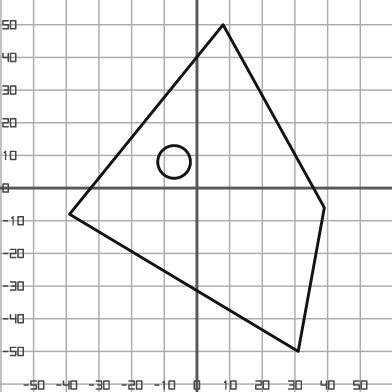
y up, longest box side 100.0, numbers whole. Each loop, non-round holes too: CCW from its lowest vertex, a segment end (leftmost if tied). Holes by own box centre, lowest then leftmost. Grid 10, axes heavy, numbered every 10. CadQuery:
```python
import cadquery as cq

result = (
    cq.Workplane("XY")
    .moveTo(31.0, -50.0)
    .lineTo(39.0, -6.0)
    .lineTo(8.0, 50.0)
    .lineTo(-39.0, -8.0)
    .close()
    .moveTo(-7.0, 8.0)
    .circle(5.0)
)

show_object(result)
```